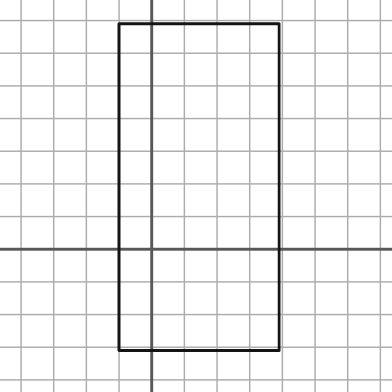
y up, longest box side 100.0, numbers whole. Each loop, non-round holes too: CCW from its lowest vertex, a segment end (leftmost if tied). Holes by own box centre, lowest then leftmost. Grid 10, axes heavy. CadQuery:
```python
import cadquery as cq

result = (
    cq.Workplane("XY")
    .moveTo(-10.0, -31.0)
    .lineTo(39.0, -31.0)
    .lineTo(39.0, 69.0)
    .lineTo(-10.0, 69.0)
    .close()
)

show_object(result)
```